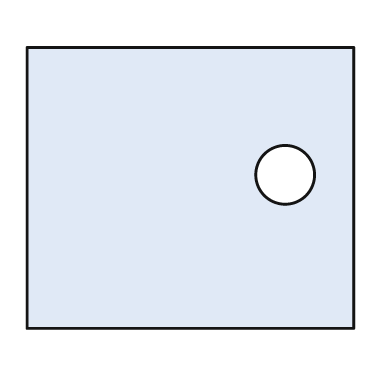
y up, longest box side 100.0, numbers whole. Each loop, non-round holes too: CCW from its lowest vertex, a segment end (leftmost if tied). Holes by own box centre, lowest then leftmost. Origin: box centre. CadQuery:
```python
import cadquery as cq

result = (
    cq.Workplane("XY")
    .moveTo(-50.0, -43.0)
    .lineTo(50.0, -43.0)
    .lineTo(50.0, 43.0)
    .lineTo(-50.0, 43.0)
    .close()
    .moveTo(29.0, 4.0)
    .circle(9.0)
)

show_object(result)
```